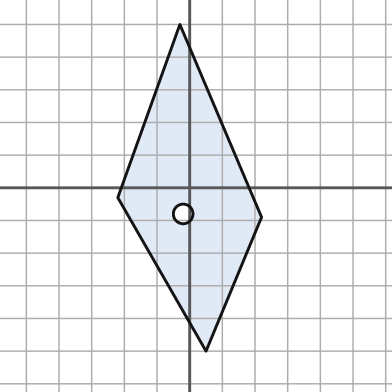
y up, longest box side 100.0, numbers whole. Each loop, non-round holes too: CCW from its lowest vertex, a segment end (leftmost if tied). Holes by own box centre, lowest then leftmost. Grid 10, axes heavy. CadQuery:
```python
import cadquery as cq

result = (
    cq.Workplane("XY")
    .moveTo(5.0, -50.0)
    .lineTo(22.0, -9.0)
    .lineTo(-3.0, 50.0)
    .lineTo(-22.0, -3.0)
    .close()
    .moveTo(-2.0, -8.0)
    .circle(3.0)
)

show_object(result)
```